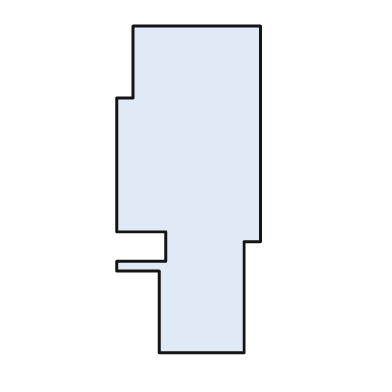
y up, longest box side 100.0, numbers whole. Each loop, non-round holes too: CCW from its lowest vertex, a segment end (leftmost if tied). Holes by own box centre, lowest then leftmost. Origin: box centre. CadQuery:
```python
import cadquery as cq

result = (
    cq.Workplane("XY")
    .moveTo(-9.0, -50.0)
    .lineTo(17.0, -50.0)
    .lineTo(17.0, -16.0)
    .lineTo(22.0, -16.0)
    .lineTo(22.0, 50.0)
    .lineTo(-17.0, 50.0)
    .lineTo(-17.0, 28.0)
    .lineTo(-22.0, 28.0)
    .lineTo(-22.0, -13.0)
    .lineTo(-7.0, -13.0)
    .lineTo(-7.0, -22.0)
    .lineTo(-22.0, -22.0)
    .lineTo(-22.0, -25.0)
    .lineTo(-9.0, -25.0)
    .close()
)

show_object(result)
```